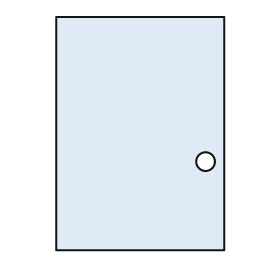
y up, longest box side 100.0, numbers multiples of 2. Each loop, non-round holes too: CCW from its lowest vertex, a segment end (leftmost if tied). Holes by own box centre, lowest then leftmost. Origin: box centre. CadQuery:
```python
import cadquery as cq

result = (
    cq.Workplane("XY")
    .moveTo(-36.0, -50.0)
    .lineTo(36.0, -50.0)
    .lineTo(36.0, 50.0)
    .lineTo(-36.0, 50.0)
    .close()
    .moveTo(28.0, -12.0)
    .circle(4.0)
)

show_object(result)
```